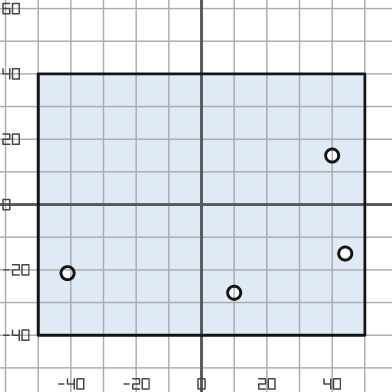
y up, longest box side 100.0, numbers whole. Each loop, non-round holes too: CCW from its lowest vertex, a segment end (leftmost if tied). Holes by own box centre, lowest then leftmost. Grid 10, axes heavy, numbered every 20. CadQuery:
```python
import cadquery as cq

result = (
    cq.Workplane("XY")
    .moveTo(-50.0, -40.0)
    .lineTo(50.0, -40.0)
    .lineTo(50.0, 40.0)
    .lineTo(-50.0, 40.0)
    .close()
    .moveTo(10.0, -27.0)
    .circle(2.0)
    .moveTo(-41.0, -21.0)
    .circle(2.0)
    .moveTo(44.0, -15.0)
    .circle(2.0)
    .moveTo(40.0, 15.0)
    .circle(2.0)
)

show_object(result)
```